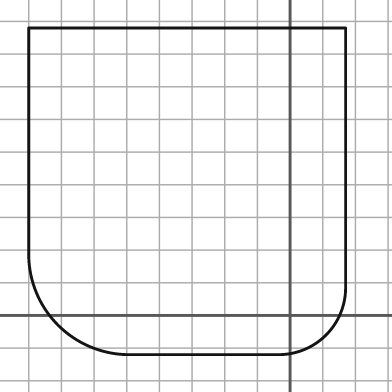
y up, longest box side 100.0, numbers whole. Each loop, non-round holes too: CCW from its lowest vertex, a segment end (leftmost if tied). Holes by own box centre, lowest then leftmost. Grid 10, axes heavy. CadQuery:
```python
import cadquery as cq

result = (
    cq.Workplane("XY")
    .moveTo(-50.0, -12.0)
    .lineTo(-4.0, -12.0)
    .threePointArc((11.0, -6.0), (17.0, 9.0))
    .lineTo(17.0, 88.0)
    .lineTo(-80.0, 88.0)
    .lineTo(-80.0, 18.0)
    .threePointArc((-71.0, -3.0), (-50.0, -12.0))
    .close()
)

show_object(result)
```